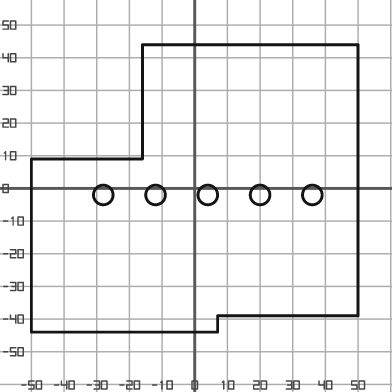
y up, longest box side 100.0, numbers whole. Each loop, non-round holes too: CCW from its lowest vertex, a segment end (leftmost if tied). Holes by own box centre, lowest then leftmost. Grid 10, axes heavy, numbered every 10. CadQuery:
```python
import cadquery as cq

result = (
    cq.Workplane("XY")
    .moveTo(-50.0, -44.0)
    .lineTo(7.0, -44.0)
    .lineTo(7.0, -39.0)
    .lineTo(50.0, -39.0)
    .lineTo(50.0, 44.0)
    .lineTo(-16.0, 44.0)
    .lineTo(-16.0, 9.0)
    .lineTo(-50.0, 9.0)
    .close()
    .moveTo(-28.0, -2.0)
    .circle(3.0)
    .moveTo(-12.0, -2.0)
    .circle(3.0)
    .moveTo(4.0, -2.0)
    .circle(3.0)
    .moveTo(20.0, -2.0)
    .circle(3.0)
    .moveTo(36.0, -2.0)
    .circle(3.0)
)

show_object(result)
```